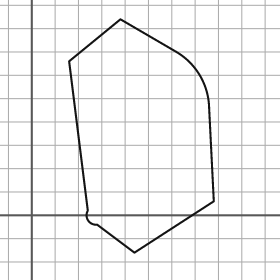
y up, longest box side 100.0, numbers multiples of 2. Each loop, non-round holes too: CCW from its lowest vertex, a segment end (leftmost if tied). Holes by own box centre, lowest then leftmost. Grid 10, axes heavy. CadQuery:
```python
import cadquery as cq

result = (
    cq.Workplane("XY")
    .moveTo(44.0, -16.0)
    .lineTo(78.0, 6.0)
    .lineTo(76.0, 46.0)
    .threePointArc((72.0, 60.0), (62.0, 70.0))
    .lineTo(38.0, 84.0)
    .lineTo(16.0, 66.0)
    .lineTo(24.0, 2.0)
    .threePointArc((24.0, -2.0), (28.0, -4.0))
    .close()
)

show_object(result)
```